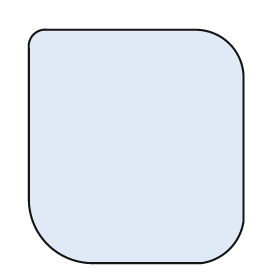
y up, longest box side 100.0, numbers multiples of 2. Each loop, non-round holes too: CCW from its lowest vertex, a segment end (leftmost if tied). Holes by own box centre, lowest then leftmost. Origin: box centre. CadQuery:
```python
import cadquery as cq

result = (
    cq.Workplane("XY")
    .moveTo(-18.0, -50.0)
    .lineTo(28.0, -50.0)
    .threePointArc((40.0, -44.0), (46.0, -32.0))
    .lineTo(46.0, 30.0)
    .threePointArc((40.0, 44.0), (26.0, 50.0))
    .lineTo(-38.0, 50.0)
    .threePointArc((-44.0, 48.0), (-46.0, 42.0))
    .lineTo(-46.0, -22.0)
    .threePointArc((-38.0, -42.0), (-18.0, -50.0))
    .close()
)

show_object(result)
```